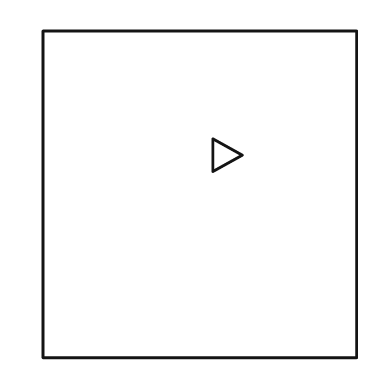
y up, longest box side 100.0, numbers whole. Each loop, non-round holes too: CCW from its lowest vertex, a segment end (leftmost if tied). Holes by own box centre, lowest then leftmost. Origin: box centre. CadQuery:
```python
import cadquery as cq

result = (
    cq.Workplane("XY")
    .moveTo(-48.0, -50.0)
    .lineTo(48.0, -50.0)
    .lineTo(48.0, 50.0)
    .lineTo(-48.0, 50.0)
    .close()
    .moveTo(4.0, 7.0)
    .lineTo(13.0, 12.0)
    .lineTo(4.0, 17.0)
    .close()
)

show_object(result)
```